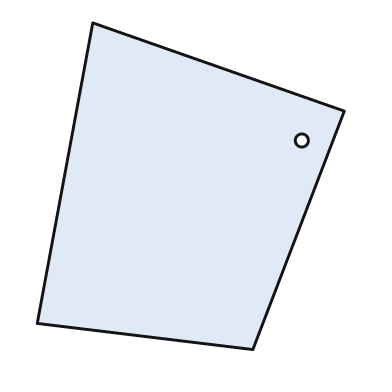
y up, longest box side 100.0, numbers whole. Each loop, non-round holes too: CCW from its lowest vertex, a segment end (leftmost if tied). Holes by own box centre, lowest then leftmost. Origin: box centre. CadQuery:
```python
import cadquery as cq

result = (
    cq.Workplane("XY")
    .moveTo(19.0, -50.0)
    .lineTo(47.0, 23.0)
    .lineTo(-30.0, 50.0)
    .lineTo(-47.0, -42.0)
    .close()
    .moveTo(34.0, 14.0)
    .circle(2.0)
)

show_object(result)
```